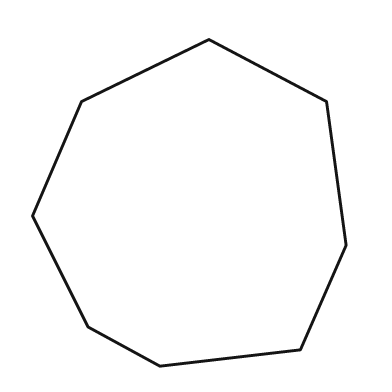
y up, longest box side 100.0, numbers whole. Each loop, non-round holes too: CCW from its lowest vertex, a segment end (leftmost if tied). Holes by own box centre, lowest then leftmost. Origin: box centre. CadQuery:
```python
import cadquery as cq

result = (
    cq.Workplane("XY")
    .moveTo(-9.0, -50.0)
    .lineTo(34.0, -45.0)
    .lineTo(48.0, -13.0)
    .lineTo(42.0, 31.0)
    .lineTo(6.0, 50.0)
    .lineTo(-33.0, 31.0)
    .lineTo(-48.0, -4.0)
    .lineTo(-31.0, -38.0)
    .close()
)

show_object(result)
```